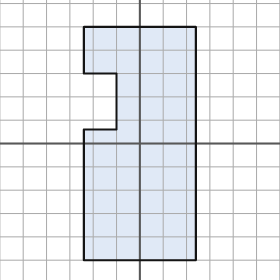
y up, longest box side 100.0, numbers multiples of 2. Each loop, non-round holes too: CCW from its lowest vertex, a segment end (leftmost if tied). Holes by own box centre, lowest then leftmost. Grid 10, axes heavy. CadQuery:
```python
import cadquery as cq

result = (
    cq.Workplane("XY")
    .moveTo(-24.0, -50.0)
    .lineTo(24.0, -50.0)
    .lineTo(24.0, 50.0)
    .lineTo(-24.0, 50.0)
    .lineTo(-24.0, 30.0)
    .lineTo(-10.0, 30.0)
    .lineTo(-10.0, 6.0)
    .lineTo(-24.0, 6.0)
    .close()
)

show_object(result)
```